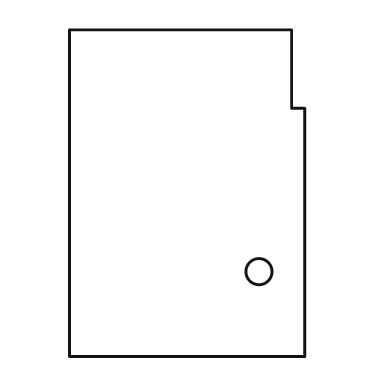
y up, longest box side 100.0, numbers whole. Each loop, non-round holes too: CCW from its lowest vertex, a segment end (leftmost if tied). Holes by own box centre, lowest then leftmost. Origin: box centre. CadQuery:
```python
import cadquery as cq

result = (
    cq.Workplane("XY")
    .moveTo(-36.0, -50.0)
    .lineTo(36.0, -50.0)
    .lineTo(36.0, 26.0)
    .lineTo(32.0, 26.0)
    .lineTo(32.0, 50.0)
    .lineTo(-36.0, 50.0)
    .close()
    .moveTo(22.0, -24.0)
    .circle(4.0)
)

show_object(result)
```